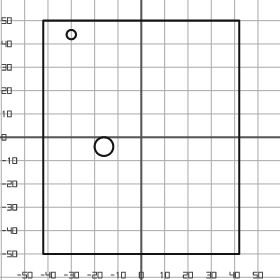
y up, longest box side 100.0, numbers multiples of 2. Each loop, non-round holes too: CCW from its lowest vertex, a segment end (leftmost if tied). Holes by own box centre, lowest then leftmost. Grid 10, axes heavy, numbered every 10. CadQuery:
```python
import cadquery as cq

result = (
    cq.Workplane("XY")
    .moveTo(-42.0, -50.0)
    .lineTo(42.0, -50.0)
    .lineTo(42.0, 50.0)
    .lineTo(-42.0, 50.0)
    .close()
    .moveTo(-16.0, -4.0)
    .circle(4.0)
    .moveTo(-30.0, 44.0)
    .circle(2.0)
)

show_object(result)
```